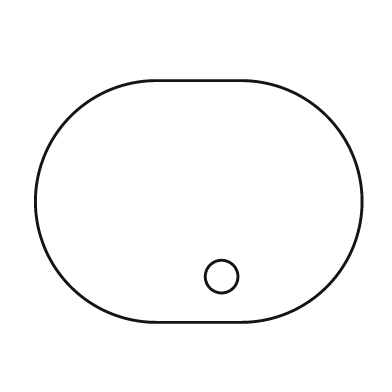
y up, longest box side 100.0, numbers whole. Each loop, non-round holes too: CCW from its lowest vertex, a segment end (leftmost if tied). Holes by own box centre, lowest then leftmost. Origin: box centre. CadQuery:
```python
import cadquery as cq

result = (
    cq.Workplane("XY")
    .moveTo(-13.0, -37.0)
    .lineTo(13.0, -37.0)
    .threePointArc((50.0, 0.0), (13.0, 37.0))
    .lineTo(-13.0, 37.0)
    .threePointArc((-50.0, 0.0), (-13.0, -37.0))
    .close()
    .moveTo(7.0, -23.0)
    .circle(5.0)
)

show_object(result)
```